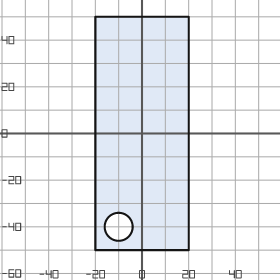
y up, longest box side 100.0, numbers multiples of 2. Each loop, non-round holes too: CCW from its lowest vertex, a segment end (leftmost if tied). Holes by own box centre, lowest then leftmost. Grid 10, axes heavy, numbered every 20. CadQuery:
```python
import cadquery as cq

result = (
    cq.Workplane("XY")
    .moveTo(-20.0, -50.0)
    .lineTo(20.0, -50.0)
    .lineTo(20.0, 50.0)
    .lineTo(-20.0, 50.0)
    .close()
    .moveTo(-10.0, -40.0)
    .circle(6.0)
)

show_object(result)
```